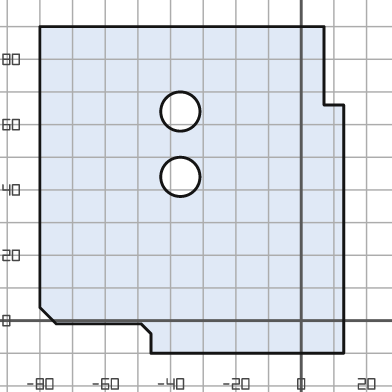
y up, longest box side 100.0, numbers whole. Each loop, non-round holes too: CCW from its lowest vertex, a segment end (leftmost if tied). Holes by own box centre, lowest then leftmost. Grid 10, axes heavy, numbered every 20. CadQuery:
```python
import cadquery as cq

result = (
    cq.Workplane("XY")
    .moveTo(-46.0, -10.0)
    .lineTo(13.0, -10.0)
    .lineTo(13.0, 66.0)
    .lineTo(7.0, 66.0)
    .lineTo(7.0, 90.0)
    .lineTo(-80.0, 90.0)
    .lineTo(-80.0, 4.0)
    .lineTo(-75.0, -1.0)
    .lineTo(-49.0, -1.0)
    .lineTo(-46.0, -4.0)
    .close()
    .moveTo(-37.0, 44.0)
    .circle(6.0)
    .moveTo(-37.0, 64.0)
    .circle(6.0)
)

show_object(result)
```